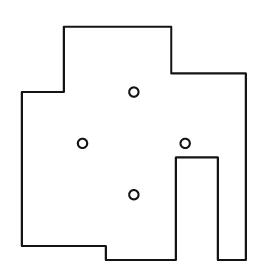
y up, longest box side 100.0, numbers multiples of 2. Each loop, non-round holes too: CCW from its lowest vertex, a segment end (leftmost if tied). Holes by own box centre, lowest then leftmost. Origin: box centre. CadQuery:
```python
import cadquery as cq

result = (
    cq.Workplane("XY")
    .moveTo(-12.0, -50.0)
    .lineTo(18.0, -50.0)
    .lineTo(18.0, -6.0)
    .lineTo(36.0, -6.0)
    .lineTo(36.0, -50.0)
    .lineTo(48.0, -50.0)
    .lineTo(48.0, 30.0)
    .lineTo(16.0, 30.0)
    .lineTo(16.0, 50.0)
    .lineTo(-30.0, 50.0)
    .lineTo(-30.0, 22.0)
    .lineTo(-48.0, 22.0)
    .lineTo(-48.0, -44.0)
    .lineTo(-12.0, -44.0)
    .close()
    .moveTo(0.0, -22.0)
    .circle(2.0)
    .moveTo(-22.0, 0.0)
    .circle(2.0)
    .moveTo(22.0, 0.0)
    .circle(2.0)
    .moveTo(0.0, 22.0)
    .circle(2.0)
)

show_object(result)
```